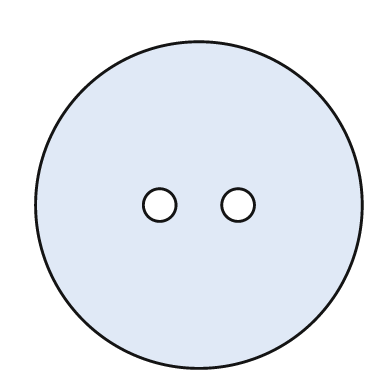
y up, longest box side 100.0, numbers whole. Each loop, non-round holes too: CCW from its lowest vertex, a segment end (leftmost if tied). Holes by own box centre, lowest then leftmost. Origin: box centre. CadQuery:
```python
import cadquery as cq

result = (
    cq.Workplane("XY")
    .moveTo(0.0, 0.0)
    .circle(50.0)
    .moveTo(-12.0, 0.0)
    .circle(5.0)
    .moveTo(12.0, 0.0)
    .circle(5.0)
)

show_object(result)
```